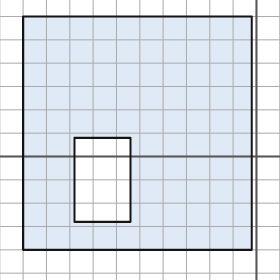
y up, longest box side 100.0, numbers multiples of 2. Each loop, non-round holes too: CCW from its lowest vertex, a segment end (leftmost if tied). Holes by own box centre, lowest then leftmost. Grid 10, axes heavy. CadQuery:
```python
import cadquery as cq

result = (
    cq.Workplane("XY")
    .moveTo(-100.0, -40.0)
    .lineTo(-2.0, -40.0)
    .lineTo(-2.0, 60.0)
    .lineTo(-100.0, 60.0)
    .close()
    .moveTo(-78.0, -28.0)
    .lineTo(-54.0, -28.0)
    .lineTo(-54.0, 8.0)
    .lineTo(-78.0, 8.0)
    .close()
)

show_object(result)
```